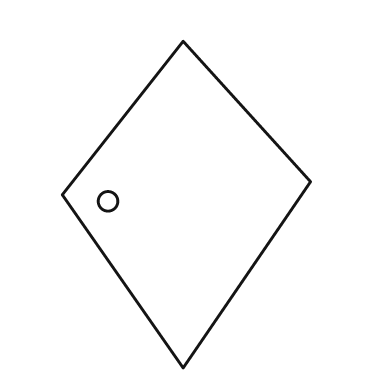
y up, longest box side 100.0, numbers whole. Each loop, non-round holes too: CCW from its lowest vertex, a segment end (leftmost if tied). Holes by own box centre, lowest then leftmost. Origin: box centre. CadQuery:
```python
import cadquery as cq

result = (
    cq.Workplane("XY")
    .moveTo(-1.0, -50.0)
    .lineTo(38.0, 7.0)
    .lineTo(-1.0, 50.0)
    .lineTo(-38.0, 3.0)
    .close()
    .moveTo(-24.0, 1.0)
    .circle(3.0)
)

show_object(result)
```